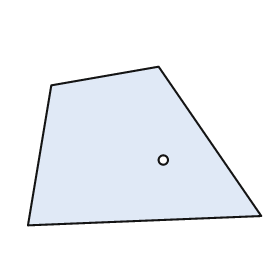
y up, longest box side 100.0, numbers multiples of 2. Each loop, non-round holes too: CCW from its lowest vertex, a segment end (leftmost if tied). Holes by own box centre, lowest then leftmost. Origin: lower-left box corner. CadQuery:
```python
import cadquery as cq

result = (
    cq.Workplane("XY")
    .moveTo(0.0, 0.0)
    .lineTo(100.0, 4.0)
    .lineTo(56.0, 68.0)
    .lineTo(10.0, 60.0)
    .close()
    .moveTo(58.0, 28.0)
    .circle(2.0)
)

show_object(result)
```